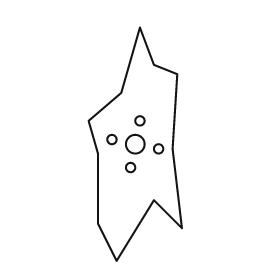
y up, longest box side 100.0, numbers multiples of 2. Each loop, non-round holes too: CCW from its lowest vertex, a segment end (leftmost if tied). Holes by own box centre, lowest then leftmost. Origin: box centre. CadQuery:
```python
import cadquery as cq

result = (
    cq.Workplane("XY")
    .moveTo(-8.0, -50.0)
    .lineTo(8.0, -24.0)
    .lineTo(20.0, -36.0)
    .lineTo(16.0, -2.0)
    .lineTo(18.0, 30.0)
    .lineTo(8.0, 34.0)
    .lineTo(2.0, 50.0)
    .lineTo(-6.0, 22.0)
    .lineTo(-20.0, 10.0)
    .lineTo(-16.0, -4.0)
    .lineTo(-16.0, -34.0)
    .close()
    .moveTo(-2.0, -10.0)
    .circle(2.0)
    .moveTo(10.0, -2.0)
    .circle(2.0)
    .moveTo(0.0, 0.0)
    .circle(4.0)
    .moveTo(-10.0, 2.0)
    .circle(2.0)
    .moveTo(2.0, 10.0)
    .circle(2.0)
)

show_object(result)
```